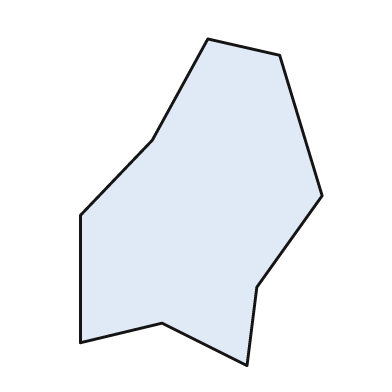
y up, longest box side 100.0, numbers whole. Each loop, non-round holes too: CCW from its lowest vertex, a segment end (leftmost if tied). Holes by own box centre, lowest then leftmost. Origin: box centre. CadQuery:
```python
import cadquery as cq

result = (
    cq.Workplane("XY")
    .moveTo(14.0, -50.0)
    .lineTo(17.0, -26.0)
    .lineTo(37.0, 2.0)
    .lineTo(24.0, 45.0)
    .lineTo(2.0, 50.0)
    .lineTo(-15.0, 19.0)
    .lineTo(-37.0, -4.0)
    .lineTo(-37.0, -43.0)
    .lineTo(-12.0, -37.0)
    .close()
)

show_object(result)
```